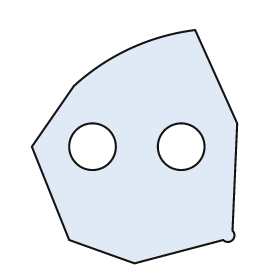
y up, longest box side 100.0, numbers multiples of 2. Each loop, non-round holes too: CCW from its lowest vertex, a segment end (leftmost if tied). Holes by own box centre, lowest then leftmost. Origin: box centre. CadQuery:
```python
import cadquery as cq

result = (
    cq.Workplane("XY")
    .moveTo(0.0, -50.0)
    .lineTo(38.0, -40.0)
    .threePointArc((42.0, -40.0), (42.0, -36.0))
    .lineTo(44.0, 10.0)
    .lineTo(26.0, 50.0)
    .threePointArc((-2.0, 42.0), (-26.0, 26.0))
    .lineTo(-44.0, 0.0)
    .lineTo(-28.0, -40.0)
    .close()
    .moveTo(-18.0, 0.0)
    .circle(10.0)
    .moveTo(20.0, 0.0)
    .circle(10.0)
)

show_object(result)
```